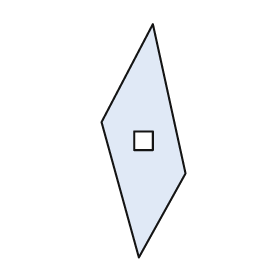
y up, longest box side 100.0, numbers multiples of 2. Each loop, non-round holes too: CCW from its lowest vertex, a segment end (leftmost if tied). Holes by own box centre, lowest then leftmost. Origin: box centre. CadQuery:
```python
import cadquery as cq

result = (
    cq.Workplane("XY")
    .moveTo(-2.0, -50.0)
    .lineTo(18.0, -14.0)
    .lineTo(4.0, 50.0)
    .lineTo(-18.0, 8.0)
    .close()
    .moveTo(-4.0, -4.0)
    .lineTo(4.0, -4.0)
    .lineTo(4.0, 4.0)
    .lineTo(-4.0, 4.0)
    .close()
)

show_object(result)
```